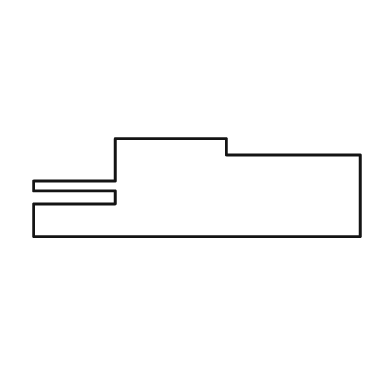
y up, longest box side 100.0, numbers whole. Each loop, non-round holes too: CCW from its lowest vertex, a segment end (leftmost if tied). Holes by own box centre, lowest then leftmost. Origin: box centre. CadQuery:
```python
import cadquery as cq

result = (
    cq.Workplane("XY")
    .moveTo(-50.0, -15.0)
    .lineTo(50.0, -15.0)
    .lineTo(50.0, 10.0)
    .lineTo(9.0, 10.0)
    .lineTo(9.0, 15.0)
    .lineTo(-25.0, 15.0)
    .lineTo(-25.0, 2.0)
    .lineTo(-50.0, 2.0)
    .lineTo(-50.0, -1.0)
    .lineTo(-25.0, -1.0)
    .lineTo(-25.0, -5.0)
    .lineTo(-50.0, -5.0)
    .close()
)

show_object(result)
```